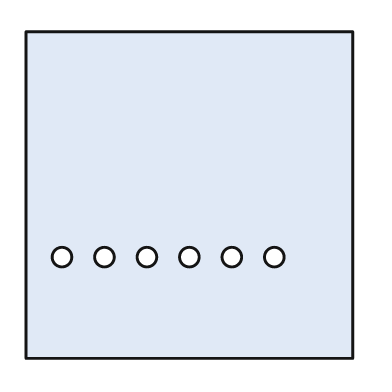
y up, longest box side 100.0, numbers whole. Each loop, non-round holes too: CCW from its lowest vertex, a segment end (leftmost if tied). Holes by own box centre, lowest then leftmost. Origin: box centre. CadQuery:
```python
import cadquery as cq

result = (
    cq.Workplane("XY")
    .moveTo(-50.0, -50.0)
    .lineTo(50.0, -50.0)
    .lineTo(50.0, 50.0)
    .lineTo(-50.0, 50.0)
    .close()
    .moveTo(-39.0, -19.0)
    .circle(3.0)
    .moveTo(-26.0, -19.0)
    .circle(3.0)
    .moveTo(-13.0, -19.0)
    .circle(3.0)
    .moveTo(0.0, -19.0)
    .circle(3.0)
    .moveTo(13.0, -19.0)
    .circle(3.0)
    .moveTo(26.0, -19.0)
    .circle(3.0)
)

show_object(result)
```